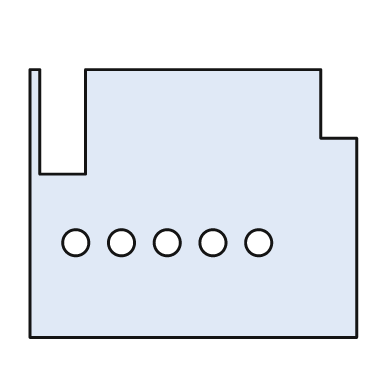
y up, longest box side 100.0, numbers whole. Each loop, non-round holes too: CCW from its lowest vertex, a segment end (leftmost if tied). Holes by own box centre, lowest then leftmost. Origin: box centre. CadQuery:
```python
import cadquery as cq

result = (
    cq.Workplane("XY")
    .moveTo(-50.0, -41.0)
    .lineTo(50.0, -41.0)
    .lineTo(50.0, 20.0)
    .lineTo(39.0, 20.0)
    .lineTo(39.0, 41.0)
    .lineTo(-33.0, 41.0)
    .lineTo(-33.0, 9.0)
    .lineTo(-47.0, 9.0)
    .lineTo(-47.0, 41.0)
    .lineTo(-50.0, 41.0)
    .close()
    .moveTo(-36.0, -12.0)
    .circle(4.0)
    .moveTo(-22.0, -12.0)
    .circle(4.0)
    .moveTo(-8.0, -12.0)
    .circle(4.0)
    .moveTo(6.0, -12.0)
    .circle(4.0)
    .moveTo(20.0, -12.0)
    .circle(4.0)
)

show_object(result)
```